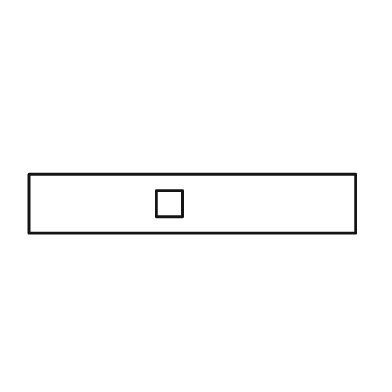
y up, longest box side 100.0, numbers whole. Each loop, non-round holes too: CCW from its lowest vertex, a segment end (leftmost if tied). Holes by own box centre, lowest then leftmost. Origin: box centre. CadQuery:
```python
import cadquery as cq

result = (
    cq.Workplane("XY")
    .moveTo(-50.0, -9.0)
    .lineTo(50.0, -9.0)
    .lineTo(50.0, 9.0)
    .lineTo(-50.0, 9.0)
    .close()
    .moveTo(-11.0, -4.0)
    .lineTo(-3.0, -4.0)
    .lineTo(-3.0, 4.0)
    .lineTo(-11.0, 4.0)
    .close()
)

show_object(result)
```